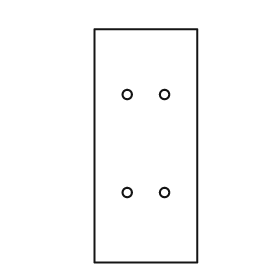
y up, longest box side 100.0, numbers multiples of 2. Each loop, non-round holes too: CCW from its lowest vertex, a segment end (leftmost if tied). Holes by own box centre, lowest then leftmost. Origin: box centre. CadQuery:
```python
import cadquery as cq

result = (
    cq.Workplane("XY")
    .moveTo(-22.0, -50.0)
    .lineTo(22.0, -50.0)
    .lineTo(22.0, 50.0)
    .lineTo(-22.0, 50.0)
    .close()
    .moveTo(-8.0, -20.0)
    .circle(2.0)
    .moveTo(8.0, -20.0)
    .circle(2.0)
    .moveTo(-8.0, 22.0)
    .circle(2.0)
    .moveTo(8.0, 22.0)
    .circle(2.0)
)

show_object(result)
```